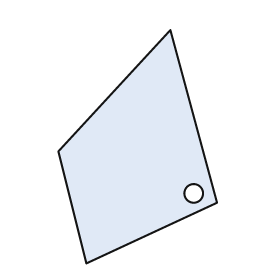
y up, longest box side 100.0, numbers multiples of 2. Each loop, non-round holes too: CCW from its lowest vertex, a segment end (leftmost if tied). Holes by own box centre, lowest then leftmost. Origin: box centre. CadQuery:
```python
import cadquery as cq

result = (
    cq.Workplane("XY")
    .moveTo(-22.0, -50.0)
    .lineTo(34.0, -24.0)
    .lineTo(14.0, 50.0)
    .lineTo(-34.0, -2.0)
    .close()
    .moveTo(24.0, -20.0)
    .circle(4.0)
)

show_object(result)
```